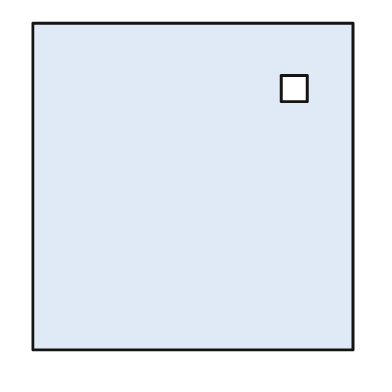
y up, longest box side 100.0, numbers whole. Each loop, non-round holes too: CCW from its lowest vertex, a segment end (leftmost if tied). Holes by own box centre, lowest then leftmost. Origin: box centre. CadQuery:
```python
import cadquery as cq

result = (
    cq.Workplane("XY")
    .moveTo(-49.0, -50.0)
    .lineTo(49.0, -50.0)
    .lineTo(49.0, 50.0)
    .lineTo(-49.0, 50.0)
    .close()
    .moveTo(27.0, 26.0)
    .lineTo(35.0, 26.0)
    .lineTo(35.0, 34.0)
    .lineTo(27.0, 34.0)
    .close()
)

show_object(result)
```